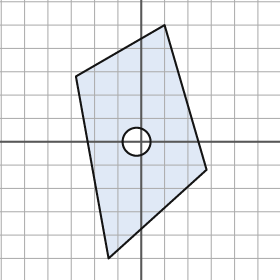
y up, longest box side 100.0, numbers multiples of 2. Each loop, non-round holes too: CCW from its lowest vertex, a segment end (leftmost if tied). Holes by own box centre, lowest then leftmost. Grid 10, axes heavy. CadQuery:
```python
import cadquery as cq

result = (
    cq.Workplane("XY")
    .moveTo(-14.0, -50.0)
    .lineTo(28.0, -12.0)
    .lineTo(10.0, 50.0)
    .lineTo(-28.0, 28.0)
    .close()
    .moveTo(-2.0, 0.0)
    .circle(6.0)
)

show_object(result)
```